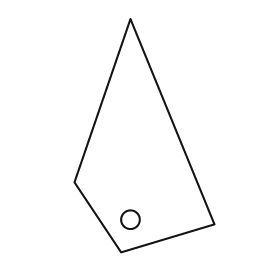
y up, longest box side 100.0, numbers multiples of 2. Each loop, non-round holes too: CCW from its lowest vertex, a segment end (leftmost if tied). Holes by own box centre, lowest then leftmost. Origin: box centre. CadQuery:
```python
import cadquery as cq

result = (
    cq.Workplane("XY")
    .moveTo(-10.0, -50.0)
    .lineTo(30.0, -38.0)
    .lineTo(-6.0, 50.0)
    .lineTo(-30.0, -20.0)
    .close()
    .moveTo(-6.0, -36.0)
    .circle(4.0)
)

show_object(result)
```